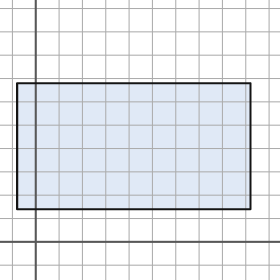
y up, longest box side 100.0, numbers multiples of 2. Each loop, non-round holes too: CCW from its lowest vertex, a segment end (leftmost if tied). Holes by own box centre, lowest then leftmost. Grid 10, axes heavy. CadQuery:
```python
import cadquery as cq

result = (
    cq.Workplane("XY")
    .moveTo(-8.0, 14.0)
    .lineTo(92.0, 14.0)
    .lineTo(92.0, 68.0)
    .lineTo(-8.0, 68.0)
    .close()
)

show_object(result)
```